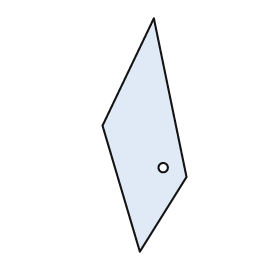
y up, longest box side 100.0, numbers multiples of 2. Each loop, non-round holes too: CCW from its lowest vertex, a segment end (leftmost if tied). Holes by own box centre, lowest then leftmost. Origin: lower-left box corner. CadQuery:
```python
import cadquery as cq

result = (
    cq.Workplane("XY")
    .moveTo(16.0, 0.0)
    .lineTo(36.0, 32.0)
    .lineTo(22.0, 100.0)
    .lineTo(0.0, 54.0)
    .close()
    .moveTo(26.0, 36.0)
    .circle(2.0)
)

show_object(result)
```